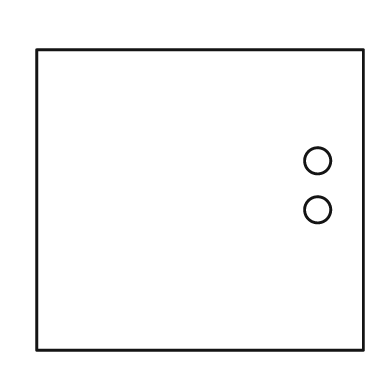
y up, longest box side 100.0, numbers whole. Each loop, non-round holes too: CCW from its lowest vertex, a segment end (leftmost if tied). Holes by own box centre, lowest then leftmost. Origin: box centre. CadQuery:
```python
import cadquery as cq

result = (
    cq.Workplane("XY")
    .moveTo(-50.0, -46.0)
    .lineTo(50.0, -46.0)
    .lineTo(50.0, 46.0)
    .lineTo(-50.0, 46.0)
    .close()
    .moveTo(36.0, -3.0)
    .circle(4.0)
    .moveTo(36.0, 12.0)
    .circle(4.0)
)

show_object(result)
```